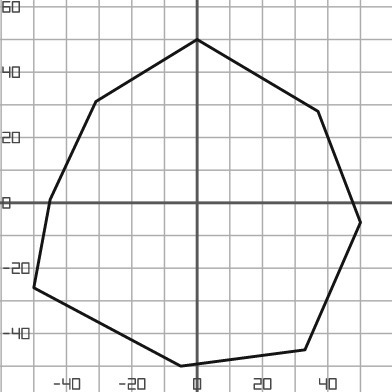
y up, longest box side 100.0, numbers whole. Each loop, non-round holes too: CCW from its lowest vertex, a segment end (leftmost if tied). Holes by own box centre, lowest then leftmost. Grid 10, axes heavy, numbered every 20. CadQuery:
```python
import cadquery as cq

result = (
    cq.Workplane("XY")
    .moveTo(-5.0, -50.0)
    .lineTo(33.0, -45.0)
    .lineTo(50.0, -6.0)
    .lineTo(37.0, 28.0)
    .lineTo(0.0, 50.0)
    .lineTo(-31.0, 31.0)
    .lineTo(-45.0, 1.0)
    .lineTo(-50.0, -26.0)
    .close()
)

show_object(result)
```